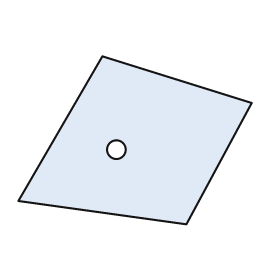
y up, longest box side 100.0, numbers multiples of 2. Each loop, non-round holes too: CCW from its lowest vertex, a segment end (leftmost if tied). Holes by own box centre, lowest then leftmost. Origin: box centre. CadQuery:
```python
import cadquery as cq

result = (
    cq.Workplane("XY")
    .moveTo(22.0, -36.0)
    .lineTo(50.0, 16.0)
    .lineTo(-14.0, 36.0)
    .lineTo(-50.0, -26.0)
    .close()
    .moveTo(-8.0, -4.0)
    .circle(4.0)
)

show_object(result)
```